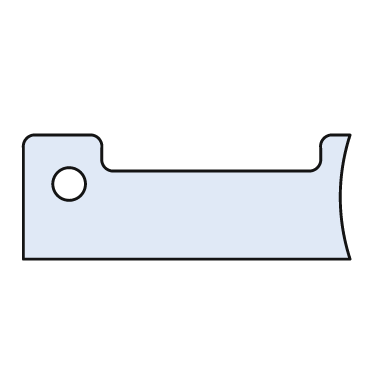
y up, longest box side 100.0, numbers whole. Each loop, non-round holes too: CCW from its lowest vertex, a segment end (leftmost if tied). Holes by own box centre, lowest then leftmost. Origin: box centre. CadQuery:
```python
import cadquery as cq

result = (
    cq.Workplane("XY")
    .moveTo(-50.0, -19.0)
    .lineTo(50.0, -19.0)
    .threePointArc((47.0, 0.0), (50.0, 19.0))
    .lineTo(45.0, 19.0)
    .threePointArc((42.0, 18.0), (41.0, 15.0))
    .lineTo(41.0, 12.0)
    .threePointArc((40.0, 9.0), (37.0, 8.0))
    .lineTo(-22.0, 8.0)
    .threePointArc((-25.0, 9.0), (-26.0, 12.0))
    .lineTo(-26.0, 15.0)
    .threePointArc((-27.0, 18.0), (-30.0, 19.0))
    .lineTo(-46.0, 19.0)
    .threePointArc((-49.0, 18.0), (-50.0, 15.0))
    .close()
    .moveTo(-36.0, 4.0)
    .circle(5.0)
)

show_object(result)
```